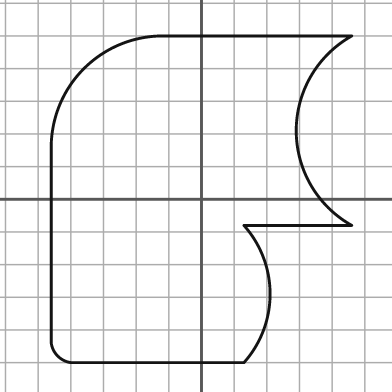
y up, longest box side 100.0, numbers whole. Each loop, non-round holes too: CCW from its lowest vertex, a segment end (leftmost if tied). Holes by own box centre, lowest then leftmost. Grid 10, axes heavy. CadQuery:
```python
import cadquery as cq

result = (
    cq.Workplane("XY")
    .moveTo(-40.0, -50.0)
    .lineTo(13.0, -50.0)
    .threePointArc((21.0, -29.0), (13.0, -8.0))
    .lineTo(46.0, -8.0)
    .threePointArc((29.0, 21.0), (46.0, 50.0))
    .lineTo(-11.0, 50.0)
    .threePointArc((-36.0, 40.0), (-46.0, 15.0))
    .lineTo(-46.0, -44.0)
    .threePointArc((-44.0, -48.0), (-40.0, -50.0))
    .close()
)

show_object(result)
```